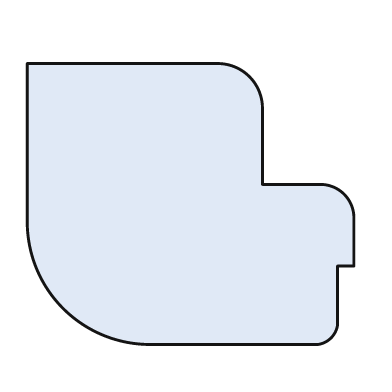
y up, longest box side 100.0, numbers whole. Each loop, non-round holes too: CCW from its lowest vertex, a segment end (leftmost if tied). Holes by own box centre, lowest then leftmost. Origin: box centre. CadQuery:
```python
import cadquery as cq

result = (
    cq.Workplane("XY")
    .moveTo(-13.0, -43.0)
    .lineTo(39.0, -43.0)
    .threePointArc((43.0, -41.0), (45.0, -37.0))
    .lineTo(45.0, -19.0)
    .lineTo(50.0, -19.0)
    .lineTo(50.0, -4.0)
    .threePointArc((47.0, 3.0), (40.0, 6.0))
    .lineTo(22.0, 6.0)
    .lineTo(22.0, 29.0)
    .threePointArc((18.0, 39.0), (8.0, 43.0))
    .lineTo(-50.0, 43.0)
    .lineTo(-50.0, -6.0)
    .threePointArc((-39.0, -32.0), (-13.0, -43.0))
    .close()
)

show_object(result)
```